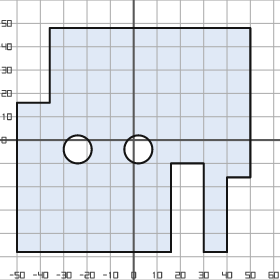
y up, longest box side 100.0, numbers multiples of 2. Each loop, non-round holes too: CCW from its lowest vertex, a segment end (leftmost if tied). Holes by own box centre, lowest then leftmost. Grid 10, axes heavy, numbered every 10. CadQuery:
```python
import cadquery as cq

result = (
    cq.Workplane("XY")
    .moveTo(-50.0, -48.0)
    .lineTo(16.0, -48.0)
    .lineTo(16.0, -10.0)
    .lineTo(30.0, -10.0)
    .lineTo(30.0, -48.0)
    .lineTo(40.0, -48.0)
    .lineTo(40.0, -16.0)
    .lineTo(50.0, -16.0)
    .lineTo(50.0, 48.0)
    .lineTo(-36.0, 48.0)
    .lineTo(-36.0, 16.0)
    .lineTo(-50.0, 16.0)
    .close()
    .moveTo(-24.0, -4.0)
    .circle(6.0)
    .moveTo(2.0, -4.0)
    .circle(6.0)
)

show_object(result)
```